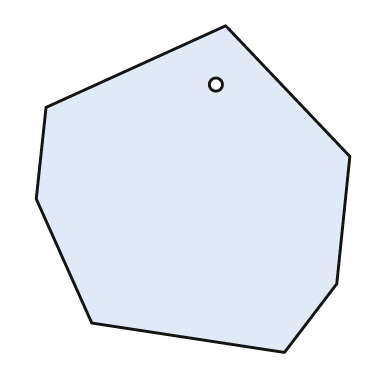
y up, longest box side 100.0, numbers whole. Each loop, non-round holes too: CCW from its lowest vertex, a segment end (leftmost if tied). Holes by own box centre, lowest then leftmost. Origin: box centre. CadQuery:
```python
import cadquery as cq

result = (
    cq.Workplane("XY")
    .moveTo(28.0, -50.0)
    .lineTo(44.0, -29.0)
    .lineTo(48.0, 10.0)
    .lineTo(10.0, 50.0)
    .lineTo(-45.0, 25.0)
    .lineTo(-48.0, -3.0)
    .lineTo(-31.0, -41.0)
    .close()
    .moveTo(7.0, 32.0)
    .circle(2.0)
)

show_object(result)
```